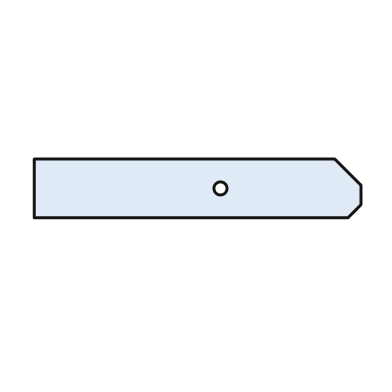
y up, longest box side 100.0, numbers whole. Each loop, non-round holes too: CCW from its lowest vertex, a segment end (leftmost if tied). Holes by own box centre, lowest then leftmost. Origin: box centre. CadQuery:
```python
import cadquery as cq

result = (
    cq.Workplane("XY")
    .moveTo(-50.0, -9.0)
    .lineTo(46.0, -9.0)
    .lineTo(50.0, -5.0)
    .lineTo(50.0, 1.0)
    .lineTo(42.0, 9.0)
    .lineTo(-50.0, 9.0)
    .close()
    .moveTo(7.0, 0.0)
    .circle(2.0)
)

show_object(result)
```